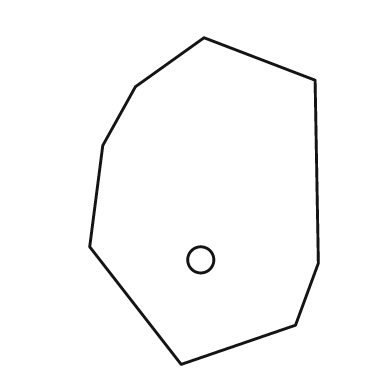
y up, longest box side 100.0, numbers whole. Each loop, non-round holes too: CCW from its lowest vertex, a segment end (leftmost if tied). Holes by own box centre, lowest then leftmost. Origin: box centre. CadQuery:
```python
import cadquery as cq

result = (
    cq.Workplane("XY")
    .moveTo(-7.0, -50.0)
    .lineTo(28.0, -38.0)
    .lineTo(35.0, -19.0)
    .lineTo(34.0, 37.0)
    .lineTo(0.0, 50.0)
    .lineTo(-21.0, 35.0)
    .lineTo(-31.0, 17.0)
    .lineTo(-35.0, -14.0)
    .close()
    .moveTo(-1.0, -18.0)
    .circle(4.0)
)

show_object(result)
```